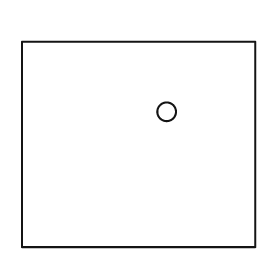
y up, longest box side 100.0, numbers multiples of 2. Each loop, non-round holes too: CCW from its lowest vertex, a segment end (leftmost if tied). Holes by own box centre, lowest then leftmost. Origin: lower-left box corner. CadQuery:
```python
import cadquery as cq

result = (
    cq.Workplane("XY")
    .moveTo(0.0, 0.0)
    .lineTo(100.0, 0.0)
    .lineTo(100.0, 88.0)
    .lineTo(0.0, 88.0)
    .close()
    .moveTo(62.0, 58.0)
    .circle(4.0)
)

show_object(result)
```